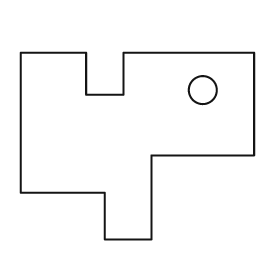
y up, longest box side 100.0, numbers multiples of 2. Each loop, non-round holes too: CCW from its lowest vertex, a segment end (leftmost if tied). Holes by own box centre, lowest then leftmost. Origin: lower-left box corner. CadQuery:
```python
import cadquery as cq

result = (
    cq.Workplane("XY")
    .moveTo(36.0, 0.0)
    .lineTo(56.0, 0.0)
    .lineTo(56.0, 36.0)
    .lineTo(100.0, 36.0)
    .lineTo(100.0, 80.0)
    .lineTo(44.0, 80.0)
    .lineTo(44.0, 62.0)
    .lineTo(28.0, 62.0)
    .lineTo(28.0, 80.0)
    .lineTo(0.0, 80.0)
    .lineTo(0.0, 20.0)
    .lineTo(36.0, 20.0)
    .close()
    .moveTo(78.0, 64.0)
    .circle(6.0)
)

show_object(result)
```